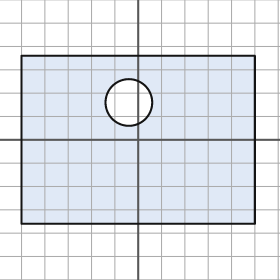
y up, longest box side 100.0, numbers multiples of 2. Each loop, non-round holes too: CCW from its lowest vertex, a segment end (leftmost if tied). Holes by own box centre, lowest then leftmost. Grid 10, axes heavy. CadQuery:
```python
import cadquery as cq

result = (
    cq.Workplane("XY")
    .moveTo(-50.0, -36.0)
    .lineTo(50.0, -36.0)
    .lineTo(50.0, 36.0)
    .lineTo(-50.0, 36.0)
    .close()
    .moveTo(-4.0, 16.0)
    .circle(10.0)
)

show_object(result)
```